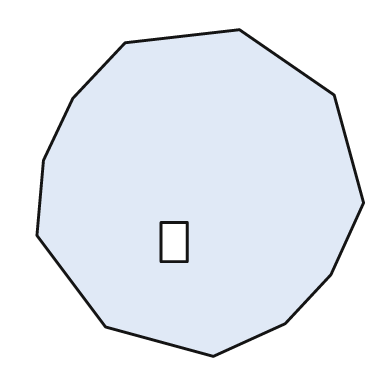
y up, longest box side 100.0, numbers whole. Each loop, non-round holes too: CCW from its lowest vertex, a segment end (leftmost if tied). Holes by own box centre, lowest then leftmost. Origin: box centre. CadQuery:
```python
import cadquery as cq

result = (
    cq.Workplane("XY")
    .moveTo(4.0, -50.0)
    .lineTo(26.0, -40.0)
    .lineTo(40.0, -25.0)
    .lineTo(50.0, -3.0)
    .lineTo(41.0, 30.0)
    .lineTo(12.0, 50.0)
    .lineTo(-23.0, 46.0)
    .lineTo(-39.0, 29.0)
    .lineTo(-48.0, 10.0)
    .lineTo(-50.0, -13.0)
    .lineTo(-29.0, -41.0)
    .close()
    .moveTo(-12.0, -21.0)
    .lineTo(-4.0, -21.0)
    .lineTo(-4.0, -9.0)
    .lineTo(-12.0, -9.0)
    .close()
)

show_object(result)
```